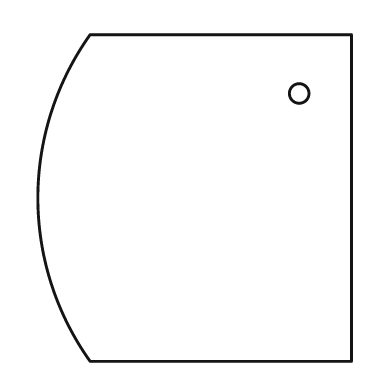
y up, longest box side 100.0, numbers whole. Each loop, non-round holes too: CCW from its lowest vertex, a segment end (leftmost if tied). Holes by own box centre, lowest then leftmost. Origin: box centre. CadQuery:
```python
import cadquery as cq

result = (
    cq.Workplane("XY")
    .moveTo(-32.0, -50.0)
    .lineTo(48.0, -50.0)
    .lineTo(48.0, 50.0)
    .lineTo(-32.0, 50.0)
    .threePointArc((-48.0, 0.0), (-32.0, -50.0))
    .close()
    .moveTo(32.0, 32.0)
    .circle(3.0)
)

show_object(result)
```